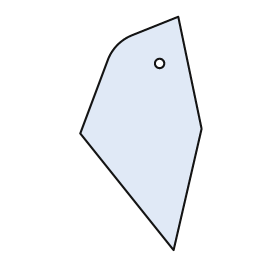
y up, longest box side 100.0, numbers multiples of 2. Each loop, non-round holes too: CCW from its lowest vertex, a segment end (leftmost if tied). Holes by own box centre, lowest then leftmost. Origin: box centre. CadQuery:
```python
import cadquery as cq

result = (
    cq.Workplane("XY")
    .moveTo(14.0, -50.0)
    .lineTo(26.0, 2.0)
    .lineTo(16.0, 50.0)
    .lineTo(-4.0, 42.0)
    .threePointArc((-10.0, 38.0), (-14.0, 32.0))
    .lineTo(-26.0, 0.0)
    .close()
    .moveTo(8.0, 30.0)
    .circle(2.0)
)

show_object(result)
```